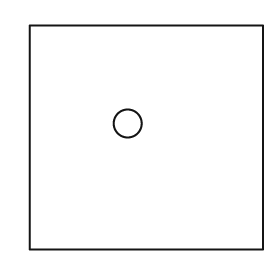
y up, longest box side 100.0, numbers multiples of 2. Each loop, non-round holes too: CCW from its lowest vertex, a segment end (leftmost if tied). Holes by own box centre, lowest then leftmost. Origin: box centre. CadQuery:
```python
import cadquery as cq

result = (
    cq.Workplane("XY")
    .moveTo(-50.0, -48.0)
    .lineTo(50.0, -48.0)
    .lineTo(50.0, 48.0)
    .lineTo(-50.0, 48.0)
    .close()
    .moveTo(-8.0, 6.0)
    .circle(6.0)
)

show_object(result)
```